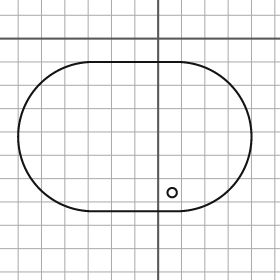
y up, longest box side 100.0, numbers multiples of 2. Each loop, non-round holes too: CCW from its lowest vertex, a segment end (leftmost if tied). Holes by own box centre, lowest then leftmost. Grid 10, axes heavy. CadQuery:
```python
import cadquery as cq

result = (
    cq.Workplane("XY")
    .moveTo(-28.0, -74.0)
    .lineTo(8.0, -74.0)
    .threePointArc((40.0, -42.0), (8.0, -10.0))
    .lineTo(-28.0, -10.0)
    .threePointArc((-60.0, -42.0), (-28.0, -74.0))
    .close()
    .moveTo(6.0, -66.0)
    .circle(2.0)
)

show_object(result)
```